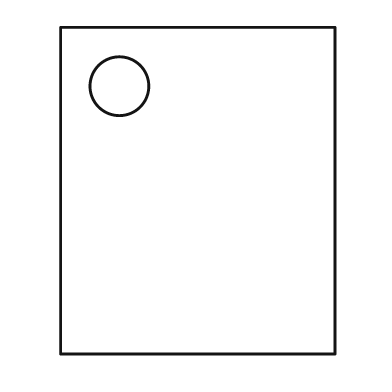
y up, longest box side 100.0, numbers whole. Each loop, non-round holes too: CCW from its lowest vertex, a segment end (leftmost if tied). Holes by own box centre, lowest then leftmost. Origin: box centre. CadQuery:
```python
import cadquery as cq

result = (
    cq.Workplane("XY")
    .moveTo(-42.0, -50.0)
    .lineTo(42.0, -50.0)
    .lineTo(42.0, 50.0)
    .lineTo(-42.0, 50.0)
    .close()
    .moveTo(-24.0, 32.0)
    .circle(9.0)
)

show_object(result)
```